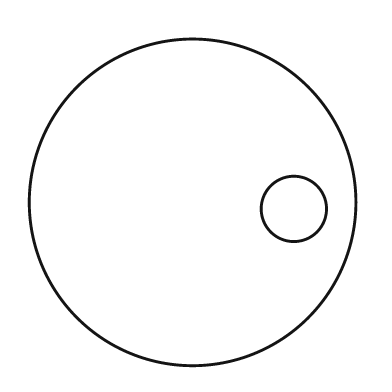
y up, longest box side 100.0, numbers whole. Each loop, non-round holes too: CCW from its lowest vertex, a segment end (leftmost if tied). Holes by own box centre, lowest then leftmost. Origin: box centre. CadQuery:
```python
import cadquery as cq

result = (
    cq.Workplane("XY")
    .moveTo(0.0, 0.0)
    .circle(50.0)
    .moveTo(31.0, -2.0)
    .circle(10.0)
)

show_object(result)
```